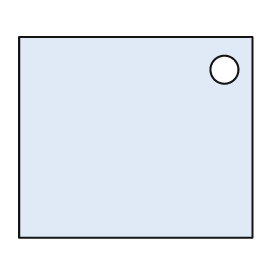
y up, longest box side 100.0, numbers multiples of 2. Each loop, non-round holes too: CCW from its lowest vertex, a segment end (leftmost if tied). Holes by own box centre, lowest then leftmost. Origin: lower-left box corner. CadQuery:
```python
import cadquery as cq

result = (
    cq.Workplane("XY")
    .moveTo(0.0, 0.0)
    .lineTo(100.0, 0.0)
    .lineTo(100.0, 86.0)
    .lineTo(0.0, 86.0)
    .close()
    .moveTo(88.0, 72.0)
    .circle(6.0)
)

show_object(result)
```